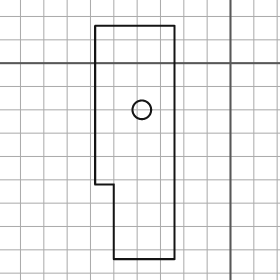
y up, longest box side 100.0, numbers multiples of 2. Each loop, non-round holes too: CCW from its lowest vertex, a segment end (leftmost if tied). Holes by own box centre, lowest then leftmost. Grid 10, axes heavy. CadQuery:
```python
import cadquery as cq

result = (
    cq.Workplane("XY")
    .moveTo(-50.0, -84.0)
    .lineTo(-24.0, -84.0)
    .lineTo(-24.0, 16.0)
    .lineTo(-58.0, 16.0)
    .lineTo(-58.0, -52.0)
    .lineTo(-50.0, -52.0)
    .close()
    .moveTo(-38.0, -20.0)
    .circle(4.0)
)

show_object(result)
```